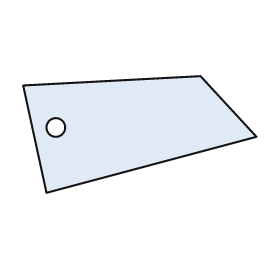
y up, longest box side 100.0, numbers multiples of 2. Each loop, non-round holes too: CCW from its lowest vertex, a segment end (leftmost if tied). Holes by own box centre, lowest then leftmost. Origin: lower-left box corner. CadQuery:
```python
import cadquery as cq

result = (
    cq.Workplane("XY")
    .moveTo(10.0, 0.0)
    .lineTo(100.0, 24.0)
    .lineTo(76.0, 50.0)
    .lineTo(0.0, 46.0)
    .close()
    .moveTo(14.0, 28.0)
    .circle(4.0)
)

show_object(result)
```